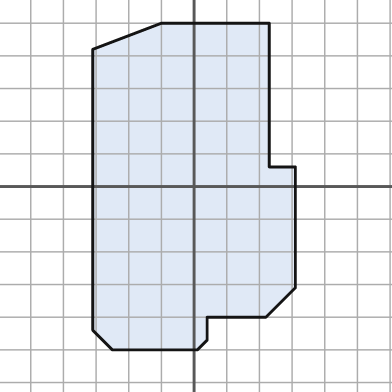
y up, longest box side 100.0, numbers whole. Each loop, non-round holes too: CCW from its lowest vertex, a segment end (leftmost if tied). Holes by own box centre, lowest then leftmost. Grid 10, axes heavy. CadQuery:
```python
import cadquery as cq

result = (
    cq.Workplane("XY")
    .moveTo(-25.0, -50.0)
    .lineTo(1.0, -50.0)
    .lineTo(4.0, -47.0)
    .lineTo(4.0, -40.0)
    .lineTo(22.0, -40.0)
    .lineTo(31.0, -31.0)
    .lineTo(31.0, 6.0)
    .lineTo(23.0, 6.0)
    .lineTo(23.0, 50.0)
    .lineTo(-10.0, 50.0)
    .lineTo(-31.0, 42.0)
    .lineTo(-31.0, -44.0)
    .close()
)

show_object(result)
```